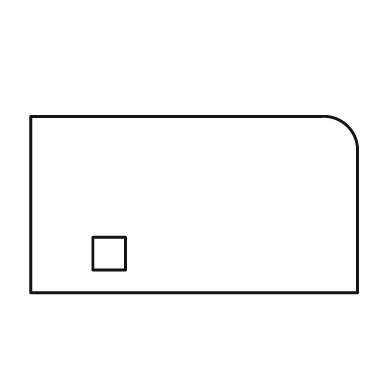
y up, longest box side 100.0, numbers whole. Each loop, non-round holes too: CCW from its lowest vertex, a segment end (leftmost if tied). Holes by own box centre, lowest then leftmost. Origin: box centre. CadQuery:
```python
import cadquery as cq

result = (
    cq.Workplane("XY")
    .moveTo(-50.0, -27.0)
    .lineTo(50.0, -27.0)
    .lineTo(50.0, 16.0)
    .threePointArc((47.0, 24.0), (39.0, 27.0))
    .lineTo(-50.0, 27.0)
    .close()
    .moveTo(-31.0, -20.0)
    .lineTo(-21.0, -20.0)
    .lineTo(-21.0, -10.0)
    .lineTo(-31.0, -10.0)
    .close()
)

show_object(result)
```